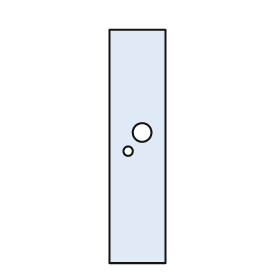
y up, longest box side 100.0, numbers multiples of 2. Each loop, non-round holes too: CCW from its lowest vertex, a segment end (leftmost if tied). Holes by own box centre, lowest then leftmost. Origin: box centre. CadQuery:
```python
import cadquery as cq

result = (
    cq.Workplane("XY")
    .moveTo(-12.0, -50.0)
    .lineTo(12.0, -50.0)
    .lineTo(12.0, 50.0)
    .lineTo(-12.0, 50.0)
    .close()
    .moveTo(-4.0, -2.0)
    .circle(2.0)
    .moveTo(2.0, 6.0)
    .circle(4.0)
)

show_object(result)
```